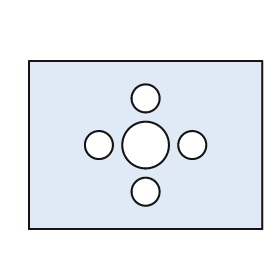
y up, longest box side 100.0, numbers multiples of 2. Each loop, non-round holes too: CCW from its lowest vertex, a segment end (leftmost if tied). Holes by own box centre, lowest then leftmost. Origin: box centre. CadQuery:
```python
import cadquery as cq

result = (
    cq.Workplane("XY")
    .moveTo(-50.0, -36.0)
    .lineTo(50.0, -36.0)
    .lineTo(50.0, 36.0)
    .lineTo(-50.0, 36.0)
    .close()
    .moveTo(0.0, -20.0)
    .circle(6.0)
    .moveTo(-20.0, 0.0)
    .circle(6.0)
    .moveTo(0.0, 0.0)
    .circle(10.0)
    .moveTo(20.0, 0.0)
    .circle(6.0)
    .moveTo(0.0, 20.0)
    .circle(6.0)
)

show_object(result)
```